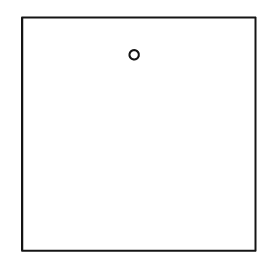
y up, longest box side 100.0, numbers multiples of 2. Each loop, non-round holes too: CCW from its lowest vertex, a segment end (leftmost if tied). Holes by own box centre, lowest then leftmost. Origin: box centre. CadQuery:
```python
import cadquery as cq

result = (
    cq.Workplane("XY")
    .moveTo(-50.0, -50.0)
    .lineTo(50.0, -50.0)
    .lineTo(50.0, 50.0)
    .lineTo(-50.0, 50.0)
    .close()
    .moveTo(-2.0, 34.0)
    .circle(2.0)
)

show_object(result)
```